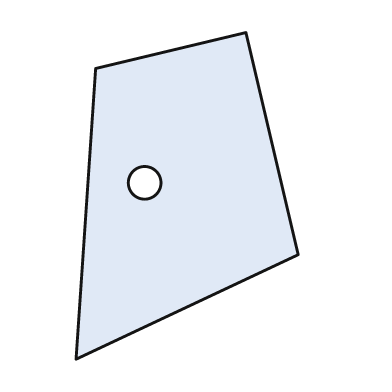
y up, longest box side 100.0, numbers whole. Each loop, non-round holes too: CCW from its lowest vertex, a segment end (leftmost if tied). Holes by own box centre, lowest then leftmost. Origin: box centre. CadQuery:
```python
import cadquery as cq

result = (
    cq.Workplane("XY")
    .moveTo(-34.0, -50.0)
    .lineTo(34.0, -18.0)
    .lineTo(18.0, 50.0)
    .lineTo(-28.0, 39.0)
    .close()
    .moveTo(-13.0, 4.0)
    .circle(5.0)
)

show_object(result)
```